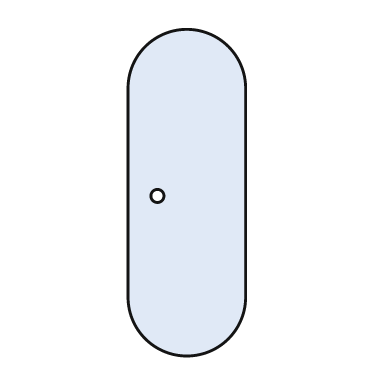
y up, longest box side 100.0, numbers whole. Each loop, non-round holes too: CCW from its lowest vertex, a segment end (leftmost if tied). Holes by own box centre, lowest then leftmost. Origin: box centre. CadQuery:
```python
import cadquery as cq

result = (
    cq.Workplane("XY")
    .moveTo(-18.0, -32.0)
    .threePointArc((0.0, -50.0), (18.0, -32.0))
    .lineTo(18.0, 32.0)
    .threePointArc((0.0, 50.0), (-18.0, 32.0))
    .close()
    .moveTo(-9.0, -1.0)
    .circle(2.0)
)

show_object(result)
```